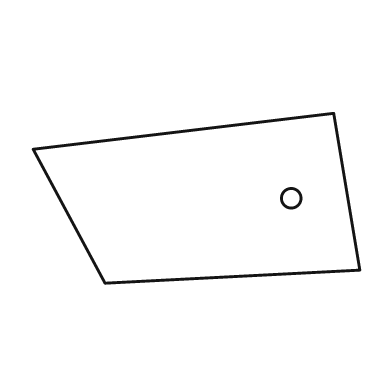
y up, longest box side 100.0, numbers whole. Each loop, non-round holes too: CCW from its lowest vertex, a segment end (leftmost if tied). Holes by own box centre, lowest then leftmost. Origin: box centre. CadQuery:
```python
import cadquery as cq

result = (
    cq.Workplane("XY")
    .moveTo(-28.0, -26.0)
    .lineTo(50.0, -22.0)
    .lineTo(42.0, 26.0)
    .lineTo(-50.0, 15.0)
    .close()
    .moveTo(29.0, 0.0)
    .circle(3.0)
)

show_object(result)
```